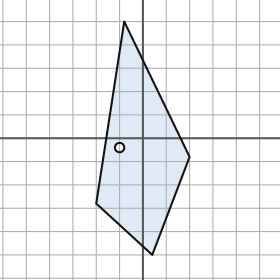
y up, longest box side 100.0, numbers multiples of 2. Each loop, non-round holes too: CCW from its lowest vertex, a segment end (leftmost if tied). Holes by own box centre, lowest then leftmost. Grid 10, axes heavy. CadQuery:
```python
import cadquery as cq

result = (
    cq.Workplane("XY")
    .moveTo(4.0, -50.0)
    .lineTo(20.0, -8.0)
    .lineTo(-8.0, 50.0)
    .lineTo(-20.0, -28.0)
    .close()
    .moveTo(-10.0, -4.0)
    .circle(2.0)
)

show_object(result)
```